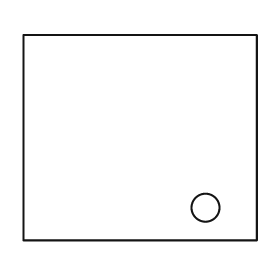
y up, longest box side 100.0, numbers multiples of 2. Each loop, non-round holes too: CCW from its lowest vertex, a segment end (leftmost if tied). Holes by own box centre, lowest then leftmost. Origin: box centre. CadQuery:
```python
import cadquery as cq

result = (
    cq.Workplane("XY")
    .moveTo(-50.0, -44.0)
    .lineTo(50.0, -44.0)
    .lineTo(50.0, 44.0)
    .lineTo(-50.0, 44.0)
    .close()
    .moveTo(28.0, -30.0)
    .circle(6.0)
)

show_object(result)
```